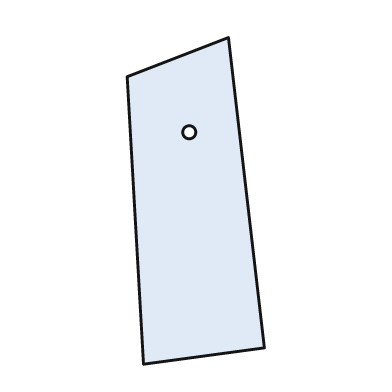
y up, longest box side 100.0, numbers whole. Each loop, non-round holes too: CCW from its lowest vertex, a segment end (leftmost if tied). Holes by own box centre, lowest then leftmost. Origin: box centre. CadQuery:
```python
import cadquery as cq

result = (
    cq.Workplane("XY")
    .moveTo(-16.0, -50.0)
    .lineTo(21.0, -45.0)
    .lineTo(10.0, 50.0)
    .lineTo(-21.0, 38.0)
    .close()
    .moveTo(-2.0, 21.0)
    .circle(2.0)
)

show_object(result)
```